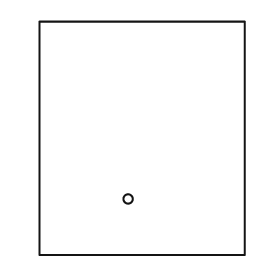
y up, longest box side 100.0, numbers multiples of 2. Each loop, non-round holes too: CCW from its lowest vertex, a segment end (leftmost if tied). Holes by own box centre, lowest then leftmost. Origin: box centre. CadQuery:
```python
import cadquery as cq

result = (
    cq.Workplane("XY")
    .moveTo(-44.0, -50.0)
    .lineTo(44.0, -50.0)
    .lineTo(44.0, 50.0)
    .lineTo(-44.0, 50.0)
    .close()
    .moveTo(-6.0, -26.0)
    .circle(2.0)
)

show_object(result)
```